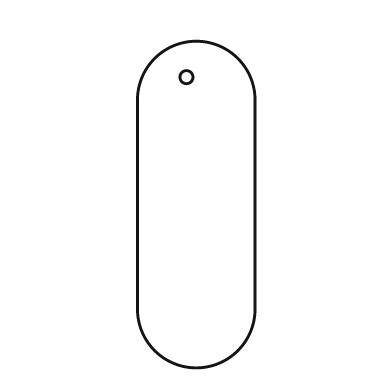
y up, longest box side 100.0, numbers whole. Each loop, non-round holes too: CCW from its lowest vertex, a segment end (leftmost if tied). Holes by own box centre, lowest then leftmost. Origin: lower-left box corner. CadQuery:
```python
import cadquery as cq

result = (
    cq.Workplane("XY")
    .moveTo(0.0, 18.0)
    .threePointArc((18.0, 0.0), (36.0, 18.0))
    .lineTo(36.0, 82.0)
    .threePointArc((18.0, 100.0), (0.0, 82.0))
    .close()
    .moveTo(15.0, 89.0)
    .circle(2.0)
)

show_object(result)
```